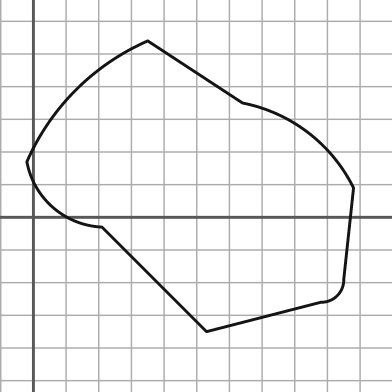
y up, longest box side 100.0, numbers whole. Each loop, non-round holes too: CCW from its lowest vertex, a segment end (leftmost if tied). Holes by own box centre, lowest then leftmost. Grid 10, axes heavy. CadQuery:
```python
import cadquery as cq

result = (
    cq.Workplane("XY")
    .moveTo(53.0, -35.0)
    .lineTo(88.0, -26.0)
    .threePointArc((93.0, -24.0), (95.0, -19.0))
    .lineTo(98.0, 9.0)
    .threePointArc((84.0, 26.0), (64.0, 35.0))
    .lineTo(35.0, 54.0)
    .threePointArc((13.0, 39.0), (-2.0, 17.0))
    .threePointArc((6.0, 3.0), (21.0, -3.0))
    .close()
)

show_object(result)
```